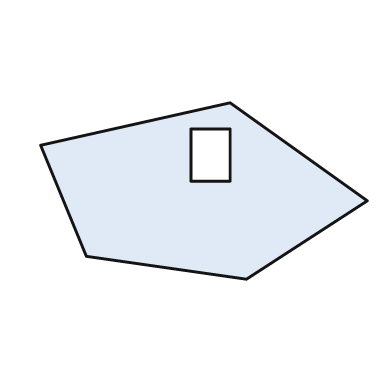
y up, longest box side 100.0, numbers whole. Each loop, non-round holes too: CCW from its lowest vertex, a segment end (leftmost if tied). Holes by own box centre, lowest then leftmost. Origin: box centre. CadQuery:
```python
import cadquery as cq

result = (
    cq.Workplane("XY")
    .moveTo(13.0, -27.0)
    .lineTo(50.0, -3.0)
    .lineTo(8.0, 27.0)
    .lineTo(-50.0, 14.0)
    .lineTo(-36.0, -20.0)
    .close()
    .moveTo(-4.0, 3.0)
    .lineTo(8.0, 3.0)
    .lineTo(8.0, 19.0)
    .lineTo(-4.0, 19.0)
    .close()
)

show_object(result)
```